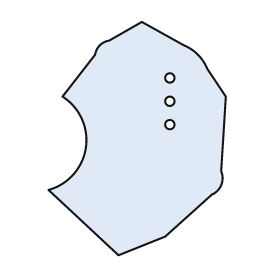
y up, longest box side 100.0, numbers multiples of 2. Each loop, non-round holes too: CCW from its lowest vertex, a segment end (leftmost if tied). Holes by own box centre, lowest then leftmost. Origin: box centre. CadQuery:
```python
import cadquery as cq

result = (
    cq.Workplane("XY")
    .moveTo(-8.0, -50.0)
    .lineTo(12.0, -42.0)
    .lineTo(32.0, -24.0)
    .threePointArc((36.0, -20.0), (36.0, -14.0))
    .lineTo(38.0, 18.0)
    .lineTo(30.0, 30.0)
    .threePointArc((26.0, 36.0), (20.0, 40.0))
    .lineTo(2.0, 50.0)
    .lineTo(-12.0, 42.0)
    .threePointArc((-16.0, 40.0), (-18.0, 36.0))
    .lineTo(-32.0, 18.0)
    .threePointArc((-22.0, -4.0), (-38.0, -22.0))
    .close()
    .moveTo(14.0, 6.0)
    .circle(2.0)
    .moveTo(14.0, 16.0)
    .circle(2.0)
    .moveTo(14.0, 26.0)
    .circle(2.0)
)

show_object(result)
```